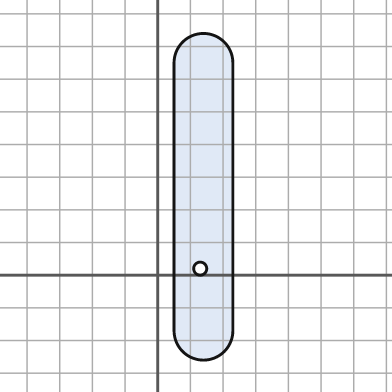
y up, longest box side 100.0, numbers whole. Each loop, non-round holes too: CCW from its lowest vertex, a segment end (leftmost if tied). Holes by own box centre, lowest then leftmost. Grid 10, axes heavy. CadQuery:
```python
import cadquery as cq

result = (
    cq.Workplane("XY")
    .moveTo(5.0, -17.0)
    .threePointArc((14.0, -26.0), (23.0, -17.0))
    .lineTo(23.0, 65.0)
    .threePointArc((14.0, 74.0), (5.0, 65.0))
    .close()
    .moveTo(13.0, 2.0)
    .circle(2.0)
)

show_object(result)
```